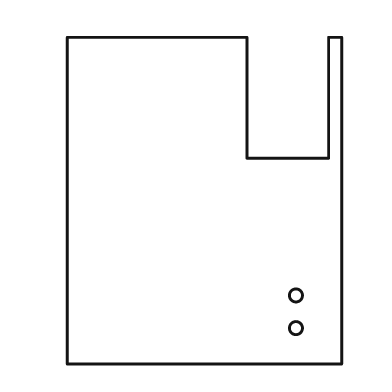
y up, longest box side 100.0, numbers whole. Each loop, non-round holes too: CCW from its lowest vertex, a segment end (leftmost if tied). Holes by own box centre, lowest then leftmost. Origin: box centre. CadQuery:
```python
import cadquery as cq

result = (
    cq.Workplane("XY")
    .moveTo(-42.0, -50.0)
    .lineTo(42.0, -50.0)
    .lineTo(42.0, 50.0)
    .lineTo(38.0, 50.0)
    .lineTo(38.0, 13.0)
    .lineTo(13.0, 13.0)
    .lineTo(13.0, 50.0)
    .lineTo(-42.0, 50.0)
    .close()
    .moveTo(28.0, -39.0)
    .circle(2.0)
    .moveTo(28.0, -29.0)
    .circle(2.0)
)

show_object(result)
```